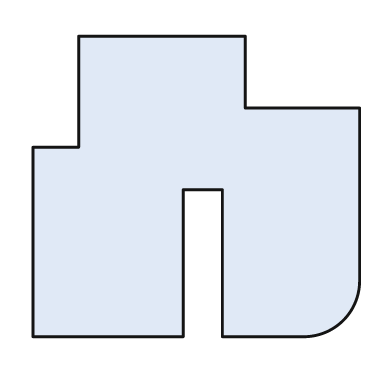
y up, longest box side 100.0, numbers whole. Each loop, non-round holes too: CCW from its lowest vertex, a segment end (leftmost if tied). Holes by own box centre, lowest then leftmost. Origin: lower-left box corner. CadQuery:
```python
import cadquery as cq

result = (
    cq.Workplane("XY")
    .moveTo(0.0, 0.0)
    .lineTo(46.0, 0.0)
    .lineTo(46.0, 45.0)
    .lineTo(58.0, 45.0)
    .lineTo(58.0, 0.0)
    .lineTo(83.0, 0.0)
    .threePointArc((95.0, 5.0), (100.0, 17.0))
    .lineTo(100.0, 70.0)
    .lineTo(65.0, 70.0)
    .lineTo(65.0, 92.0)
    .lineTo(14.0, 92.0)
    .lineTo(14.0, 58.0)
    .lineTo(0.0, 58.0)
    .close()
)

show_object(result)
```